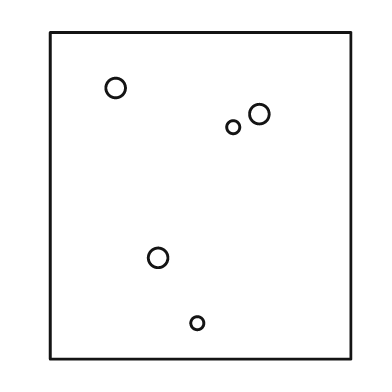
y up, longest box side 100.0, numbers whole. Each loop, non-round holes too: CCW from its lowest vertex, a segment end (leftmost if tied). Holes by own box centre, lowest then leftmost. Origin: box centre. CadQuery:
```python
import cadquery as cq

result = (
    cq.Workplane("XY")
    .moveTo(-46.0, -50.0)
    .lineTo(46.0, -50.0)
    .lineTo(46.0, 50.0)
    .lineTo(-46.0, 50.0)
    .close()
    .moveTo(-1.0, -39.0)
    .circle(2.0)
    .moveTo(-13.0, -19.0)
    .circle(3.0)
    .moveTo(10.0, 21.0)
    .circle(2.0)
    .moveTo(18.0, 25.0)
    .circle(3.0)
    .moveTo(-26.0, 33.0)
    .circle(3.0)
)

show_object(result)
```